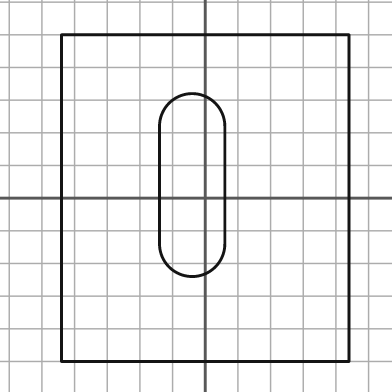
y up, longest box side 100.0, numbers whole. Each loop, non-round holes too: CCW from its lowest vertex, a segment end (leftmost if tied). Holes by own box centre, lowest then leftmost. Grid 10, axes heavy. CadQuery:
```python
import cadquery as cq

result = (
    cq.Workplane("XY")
    .moveTo(-44.0, -50.0)
    .lineTo(44.0, -50.0)
    .lineTo(44.0, 50.0)
    .lineTo(-44.0, 50.0)
    .close()
    .moveTo(-14.0, -14.0)
    .threePointArc((-4.0, -24.0), (6.0, -14.0))
    .lineTo(6.0, 22.0)
    .threePointArc((-4.0, 32.0), (-14.0, 22.0))
    .close()
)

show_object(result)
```